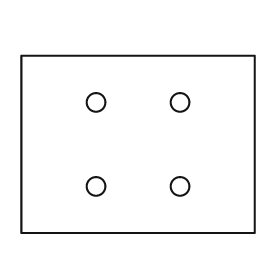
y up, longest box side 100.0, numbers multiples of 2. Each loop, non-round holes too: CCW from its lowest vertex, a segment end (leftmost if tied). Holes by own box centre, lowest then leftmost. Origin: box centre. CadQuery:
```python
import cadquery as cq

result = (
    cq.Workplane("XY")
    .moveTo(-50.0, -38.0)
    .lineTo(50.0, -38.0)
    .lineTo(50.0, 38.0)
    .lineTo(-50.0, 38.0)
    .close()
    .moveTo(-18.0, -18.0)
    .circle(4.0)
    .moveTo(18.0, -18.0)
    .circle(4.0)
    .moveTo(-18.0, 18.0)
    .circle(4.0)
    .moveTo(18.0, 18.0)
    .circle(4.0)
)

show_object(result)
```